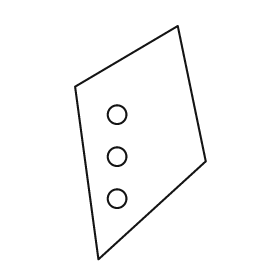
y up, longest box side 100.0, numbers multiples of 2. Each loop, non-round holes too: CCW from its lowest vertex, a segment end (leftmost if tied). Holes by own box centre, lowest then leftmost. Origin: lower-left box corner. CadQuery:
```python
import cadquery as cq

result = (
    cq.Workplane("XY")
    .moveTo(10.0, 0.0)
    .lineTo(56.0, 42.0)
    .lineTo(44.0, 100.0)
    .lineTo(0.0, 74.0)
    .close()
    .moveTo(18.0, 26.0)
    .circle(4.0)
    .moveTo(18.0, 44.0)
    .circle(4.0)
    .moveTo(18.0, 62.0)
    .circle(4.0)
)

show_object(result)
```